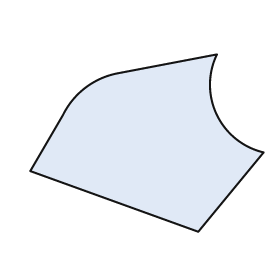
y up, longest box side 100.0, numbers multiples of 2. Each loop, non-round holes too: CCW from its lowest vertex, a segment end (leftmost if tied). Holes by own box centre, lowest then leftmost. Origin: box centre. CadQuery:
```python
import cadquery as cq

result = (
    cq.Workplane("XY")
    .moveTo(22.0, -38.0)
    .lineTo(50.0, -4.0)
    .threePointArc((30.0, 12.0), (30.0, 38.0))
    .lineTo(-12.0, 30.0)
    .threePointArc((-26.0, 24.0), (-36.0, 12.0))
    .lineTo(-50.0, -12.0)
    .close()
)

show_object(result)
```